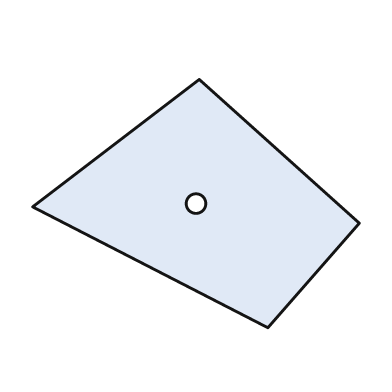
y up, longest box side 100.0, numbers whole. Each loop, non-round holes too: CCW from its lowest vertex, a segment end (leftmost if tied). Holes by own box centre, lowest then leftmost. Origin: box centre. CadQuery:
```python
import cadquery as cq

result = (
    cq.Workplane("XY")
    .moveTo(22.0, -38.0)
    .lineTo(50.0, -6.0)
    .lineTo(1.0, 38.0)
    .lineTo(-50.0, -1.0)
    .close()
    .moveTo(0.0, 0.0)
    .circle(3.0)
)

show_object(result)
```